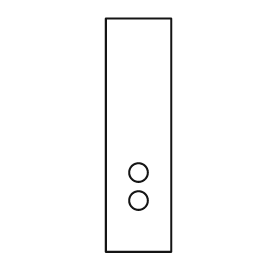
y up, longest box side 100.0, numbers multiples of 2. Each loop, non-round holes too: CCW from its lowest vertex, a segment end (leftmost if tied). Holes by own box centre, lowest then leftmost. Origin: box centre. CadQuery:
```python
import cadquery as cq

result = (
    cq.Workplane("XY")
    .moveTo(-14.0, -50.0)
    .lineTo(14.0, -50.0)
    .lineTo(14.0, 50.0)
    .lineTo(-14.0, 50.0)
    .close()
    .moveTo(0.0, -28.0)
    .circle(4.0)
    .moveTo(0.0, -16.0)
    .circle(4.0)
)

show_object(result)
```